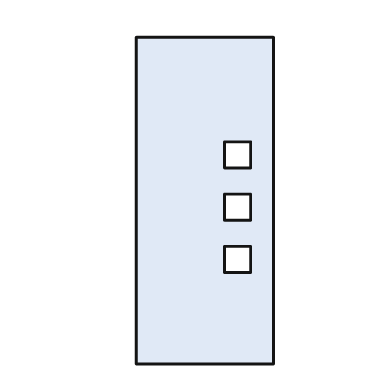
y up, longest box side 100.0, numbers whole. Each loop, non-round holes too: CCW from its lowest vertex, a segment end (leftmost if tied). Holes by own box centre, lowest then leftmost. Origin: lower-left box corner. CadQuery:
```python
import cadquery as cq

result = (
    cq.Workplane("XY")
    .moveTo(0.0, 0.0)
    .lineTo(42.0, 0.0)
    .lineTo(42.0, 100.0)
    .lineTo(0.0, 100.0)
    .close()
    .moveTo(27.0, 28.0)
    .lineTo(35.0, 28.0)
    .lineTo(35.0, 36.0)
    .lineTo(27.0, 36.0)
    .close()
    .moveTo(27.0, 44.0)
    .lineTo(35.0, 44.0)
    .lineTo(35.0, 52.0)
    .lineTo(27.0, 52.0)
    .close()
    .moveTo(27.0, 60.0)
    .lineTo(35.0, 60.0)
    .lineTo(35.0, 68.0)
    .lineTo(27.0, 68.0)
    .close()
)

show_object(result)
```